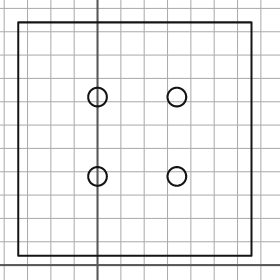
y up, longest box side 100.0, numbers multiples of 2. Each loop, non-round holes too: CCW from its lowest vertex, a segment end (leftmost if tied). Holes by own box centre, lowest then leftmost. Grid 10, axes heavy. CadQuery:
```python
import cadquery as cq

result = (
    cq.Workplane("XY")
    .moveTo(-34.0, 4.0)
    .lineTo(66.0, 4.0)
    .lineTo(66.0, 104.0)
    .lineTo(-34.0, 104.0)
    .close()
    .moveTo(0.0, 38.0)
    .circle(4.0)
    .moveTo(34.0, 38.0)
    .circle(4.0)
    .moveTo(0.0, 72.0)
    .circle(4.0)
    .moveTo(34.0, 72.0)
    .circle(4.0)
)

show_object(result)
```